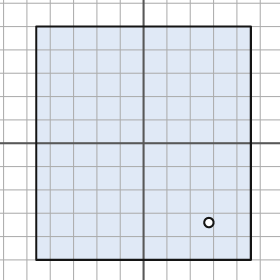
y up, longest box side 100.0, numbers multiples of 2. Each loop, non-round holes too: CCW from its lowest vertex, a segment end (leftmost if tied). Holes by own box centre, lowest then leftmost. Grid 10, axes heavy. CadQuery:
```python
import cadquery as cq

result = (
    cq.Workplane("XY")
    .moveTo(-46.0, -50.0)
    .lineTo(46.0, -50.0)
    .lineTo(46.0, 50.0)
    .lineTo(-46.0, 50.0)
    .close()
    .moveTo(28.0, -34.0)
    .circle(2.0)
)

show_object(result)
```